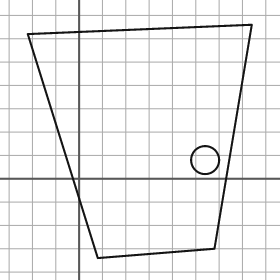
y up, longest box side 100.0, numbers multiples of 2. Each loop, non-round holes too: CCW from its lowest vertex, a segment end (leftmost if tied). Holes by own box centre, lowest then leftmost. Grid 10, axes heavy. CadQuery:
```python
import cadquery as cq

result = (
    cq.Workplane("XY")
    .moveTo(8.0, -34.0)
    .lineTo(58.0, -30.0)
    .lineTo(74.0, 66.0)
    .lineTo(-22.0, 62.0)
    .close()
    .moveTo(54.0, 8.0)
    .circle(6.0)
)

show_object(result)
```